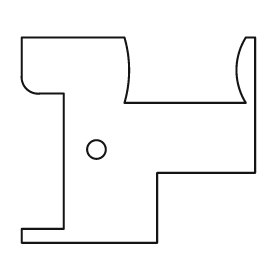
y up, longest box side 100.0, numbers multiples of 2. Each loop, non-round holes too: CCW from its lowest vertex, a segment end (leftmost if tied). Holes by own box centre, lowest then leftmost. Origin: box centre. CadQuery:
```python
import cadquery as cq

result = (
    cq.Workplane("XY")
    .moveTo(-50.0, -44.0)
    .lineTo(8.0, -44.0)
    .lineTo(8.0, -14.0)
    .lineTo(50.0, -14.0)
    .lineTo(50.0, 44.0)
    .lineTo(46.0, 44.0)
    .threePointArc((42.0, 30.0), (46.0, 16.0))
    .lineTo(-6.0, 16.0)
    .threePointArc((-4.0, 30.0), (-6.0, 44.0))
    .lineTo(-50.0, 44.0)
    .lineTo(-50.0, 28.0)
    .threePointArc((-48.0, 22.0), (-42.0, 20.0))
    .lineTo(-32.0, 20.0)
    .lineTo(-32.0, -38.0)
    .lineTo(-50.0, -38.0)
    .close()
    .moveTo(-18.0, -4.0)
    .circle(4.0)
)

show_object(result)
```